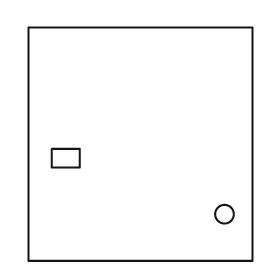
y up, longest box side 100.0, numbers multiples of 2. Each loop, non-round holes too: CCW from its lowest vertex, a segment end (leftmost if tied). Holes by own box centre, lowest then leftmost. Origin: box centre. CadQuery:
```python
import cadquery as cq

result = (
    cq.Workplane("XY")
    .moveTo(-48.0, -50.0)
    .lineTo(48.0, -50.0)
    .lineTo(48.0, 50.0)
    .lineTo(-48.0, 50.0)
    .close()
    .moveTo(36.0, -30.0)
    .circle(4.0)
    .moveTo(-38.0, -10.0)
    .lineTo(-26.0, -10.0)
    .lineTo(-26.0, -2.0)
    .lineTo(-38.0, -2.0)
    .close()
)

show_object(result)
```